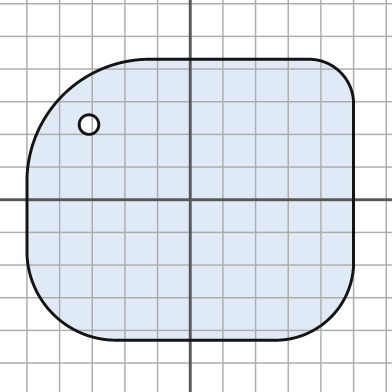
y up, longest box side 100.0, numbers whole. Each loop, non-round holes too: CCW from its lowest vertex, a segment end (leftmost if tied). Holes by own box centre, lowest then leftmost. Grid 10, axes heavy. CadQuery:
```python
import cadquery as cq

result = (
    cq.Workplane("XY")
    .moveTo(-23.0, -43.0)
    .lineTo(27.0, -43.0)
    .threePointArc((43.0, -36.0), (50.0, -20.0))
    .lineTo(50.0, 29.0)
    .threePointArc((46.0, 39.0), (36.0, 43.0))
    .lineTo(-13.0, 43.0)
    .threePointArc((-39.0, 32.0), (-50.0, 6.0))
    .lineTo(-50.0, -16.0)
    .threePointArc((-42.0, -35.0), (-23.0, -43.0))
    .close()
    .moveTo(-31.0, 23.0)
    .circle(3.0)
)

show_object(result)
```